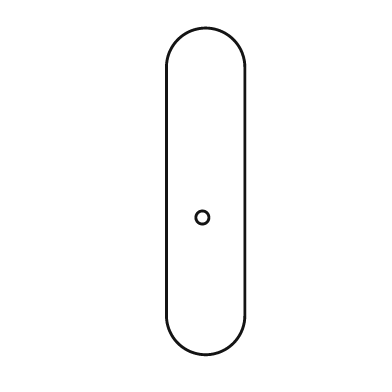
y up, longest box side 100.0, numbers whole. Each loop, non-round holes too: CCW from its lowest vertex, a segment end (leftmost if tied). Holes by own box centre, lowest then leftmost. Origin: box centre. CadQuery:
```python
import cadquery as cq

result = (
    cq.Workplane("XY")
    .moveTo(-12.0, -38.0)
    .threePointArc((0.0, -50.0), (12.0, -38.0))
    .lineTo(12.0, 38.0)
    .threePointArc((0.0, 50.0), (-12.0, 38.0))
    .close()
    .moveTo(-1.0, -8.0)
    .circle(2.0)
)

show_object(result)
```